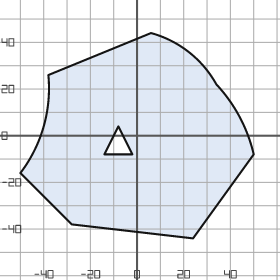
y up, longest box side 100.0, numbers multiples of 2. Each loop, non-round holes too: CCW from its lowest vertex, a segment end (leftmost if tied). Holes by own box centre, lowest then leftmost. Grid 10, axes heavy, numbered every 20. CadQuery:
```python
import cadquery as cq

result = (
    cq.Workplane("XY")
    .moveTo(24.0, -44.0)
    .lineTo(50.0, -8.0)
    .threePointArc((44.0, 8.0), (34.0, 22.0))
    .threePointArc((22.0, 36.0), (6.0, 44.0))
    .lineTo(-38.0, 26.0)
    .threePointArc((-40.0, 4.0), (-50.0, -16.0))
    .lineTo(-28.0, -38.0)
    .close()
    .moveTo(-14.0, -8.0)
    .lineTo(-2.0, -8.0)
    .lineTo(-8.0, 4.0)
    .close()
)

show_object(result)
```